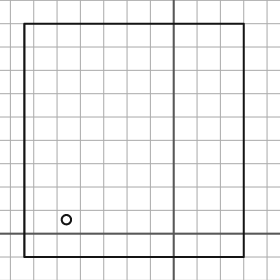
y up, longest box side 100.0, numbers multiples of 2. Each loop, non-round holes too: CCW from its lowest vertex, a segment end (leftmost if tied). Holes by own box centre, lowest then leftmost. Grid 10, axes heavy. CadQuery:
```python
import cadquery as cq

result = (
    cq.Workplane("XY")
    .moveTo(-64.0, -10.0)
    .lineTo(30.0, -10.0)
    .lineTo(30.0, 90.0)
    .lineTo(-64.0, 90.0)
    .close()
    .moveTo(-46.0, 6.0)
    .circle(2.0)
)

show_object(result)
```